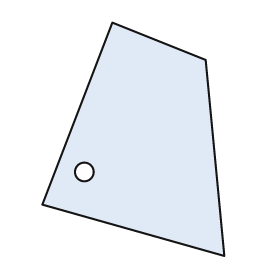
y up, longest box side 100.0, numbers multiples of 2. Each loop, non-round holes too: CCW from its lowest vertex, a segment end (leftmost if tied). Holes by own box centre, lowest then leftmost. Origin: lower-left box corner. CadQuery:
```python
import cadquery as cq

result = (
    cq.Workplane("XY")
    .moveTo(78.0, 0.0)
    .lineTo(70.0, 84.0)
    .lineTo(30.0, 100.0)
    .lineTo(0.0, 22.0)
    .close()
    .moveTo(18.0, 36.0)
    .circle(4.0)
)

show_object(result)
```